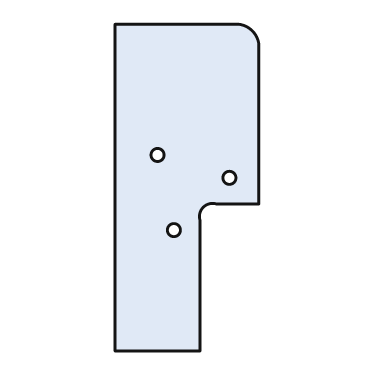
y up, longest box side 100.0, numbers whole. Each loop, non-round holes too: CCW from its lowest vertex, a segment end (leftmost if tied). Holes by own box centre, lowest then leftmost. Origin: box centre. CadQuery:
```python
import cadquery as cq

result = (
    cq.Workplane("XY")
    .moveTo(-22.0, -50.0)
    .lineTo(4.0, -50.0)
    .lineTo(4.0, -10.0)
    .threePointArc((5.0, -6.0), (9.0, -5.0))
    .lineTo(22.0, -5.0)
    .lineTo(22.0, 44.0)
    .threePointArc((20.0, 48.0), (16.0, 50.0))
    .lineTo(-22.0, 50.0)
    .close()
    .moveTo(-4.0, -13.0)
    .circle(2.0)
    .moveTo(13.0, 3.0)
    .circle(2.0)
    .moveTo(-9.0, 10.0)
    .circle(2.0)
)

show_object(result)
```